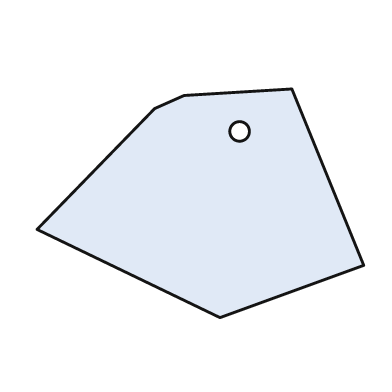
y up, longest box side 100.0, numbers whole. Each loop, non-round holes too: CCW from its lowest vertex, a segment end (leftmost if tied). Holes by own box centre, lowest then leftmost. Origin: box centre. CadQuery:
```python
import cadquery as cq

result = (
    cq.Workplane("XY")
    .moveTo(6.0, -35.0)
    .lineTo(50.0, -19.0)
    .lineTo(28.0, 35.0)
    .lineTo(-5.0, 33.0)
    .lineTo(-14.0, 29.0)
    .lineTo(-50.0, -8.0)
    .close()
    .moveTo(12.0, 22.0)
    .circle(3.0)
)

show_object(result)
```